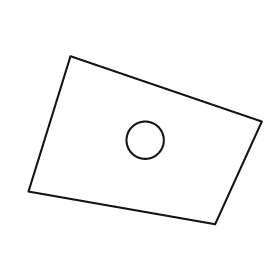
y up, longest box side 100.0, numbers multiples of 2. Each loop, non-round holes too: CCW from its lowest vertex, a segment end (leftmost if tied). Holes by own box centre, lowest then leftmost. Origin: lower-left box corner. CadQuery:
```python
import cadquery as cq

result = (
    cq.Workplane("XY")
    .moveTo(80.0, 0.0)
    .lineTo(100.0, 44.0)
    .lineTo(18.0, 72.0)
    .lineTo(0.0, 14.0)
    .close()
    .moveTo(50.0, 36.0)
    .circle(8.0)
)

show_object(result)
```